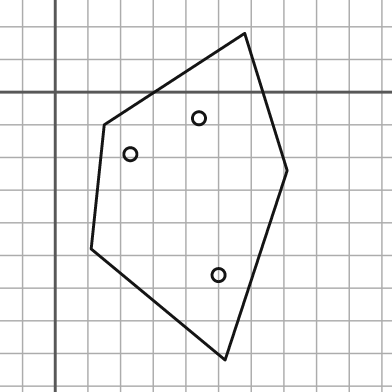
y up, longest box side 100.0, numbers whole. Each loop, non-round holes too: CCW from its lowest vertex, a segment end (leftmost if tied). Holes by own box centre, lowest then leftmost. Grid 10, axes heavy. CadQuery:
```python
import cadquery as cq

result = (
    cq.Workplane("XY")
    .moveTo(52.0, -82.0)
    .lineTo(71.0, -24.0)
    .lineTo(58.0, 18.0)
    .lineTo(15.0, -10.0)
    .lineTo(11.0, -48.0)
    .close()
    .moveTo(50.0, -56.0)
    .circle(2.0)
    .moveTo(23.0, -19.0)
    .circle(2.0)
    .moveTo(44.0, -8.0)
    .circle(2.0)
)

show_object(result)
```